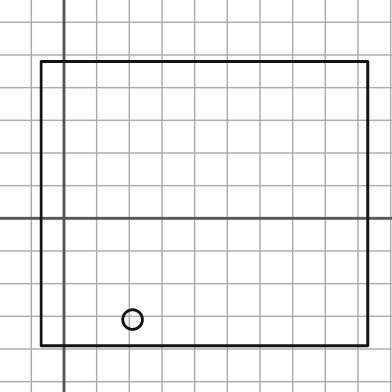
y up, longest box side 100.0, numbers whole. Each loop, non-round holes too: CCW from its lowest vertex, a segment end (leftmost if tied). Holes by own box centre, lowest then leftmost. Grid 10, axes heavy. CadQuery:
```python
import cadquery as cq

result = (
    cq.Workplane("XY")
    .moveTo(-7.0, -39.0)
    .lineTo(93.0, -39.0)
    .lineTo(93.0, 48.0)
    .lineTo(-7.0, 48.0)
    .close()
    .moveTo(21.0, -31.0)
    .circle(3.0)
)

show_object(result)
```